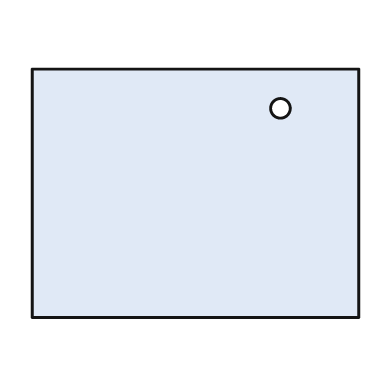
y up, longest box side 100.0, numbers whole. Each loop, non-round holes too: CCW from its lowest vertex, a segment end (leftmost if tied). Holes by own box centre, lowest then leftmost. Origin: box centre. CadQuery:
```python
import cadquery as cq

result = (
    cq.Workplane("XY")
    .moveTo(-50.0, -38.0)
    .lineTo(50.0, -38.0)
    .lineTo(50.0, 38.0)
    .lineTo(-50.0, 38.0)
    .close()
    .moveTo(26.0, 26.0)
    .circle(3.0)
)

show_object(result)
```